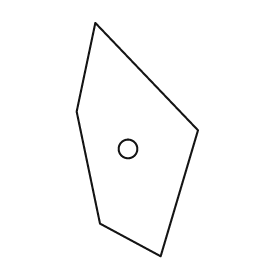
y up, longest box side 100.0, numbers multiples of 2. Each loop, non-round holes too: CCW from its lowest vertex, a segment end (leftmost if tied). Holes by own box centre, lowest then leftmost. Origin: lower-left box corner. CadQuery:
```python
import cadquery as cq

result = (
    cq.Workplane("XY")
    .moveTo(36.0, 0.0)
    .lineTo(52.0, 54.0)
    .lineTo(8.0, 100.0)
    .lineTo(0.0, 62.0)
    .lineTo(10.0, 14.0)
    .close()
    .moveTo(22.0, 46.0)
    .circle(4.0)
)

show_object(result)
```